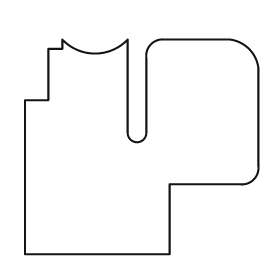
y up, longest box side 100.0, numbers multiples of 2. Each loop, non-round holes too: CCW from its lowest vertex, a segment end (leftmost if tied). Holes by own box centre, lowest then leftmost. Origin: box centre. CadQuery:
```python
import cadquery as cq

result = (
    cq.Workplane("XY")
    .moveTo(-50.0, -46.0)
    .lineTo(12.0, -46.0)
    .lineTo(12.0, -16.0)
    .lineTo(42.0, -16.0)
    .threePointArc((48.0, -14.0), (50.0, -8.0))
    .lineTo(50.0, 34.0)
    .threePointArc((46.0, 42.0), (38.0, 46.0))
    .lineTo(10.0, 46.0)
    .threePointArc((4.0, 44.0), (2.0, 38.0))
    .lineTo(2.0, 6.0)
    .threePointArc((-2.0, 2.0), (-6.0, 6.0))
    .lineTo(-6.0, 46.0)
    .threePointArc((-20.0, 40.0), (-34.0, 46.0))
    .lineTo(-34.0, 42.0)
    .lineTo(-40.0, 42.0)
    .lineTo(-40.0, 20.0)
    .lineTo(-50.0, 20.0)
    .close()
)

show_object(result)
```